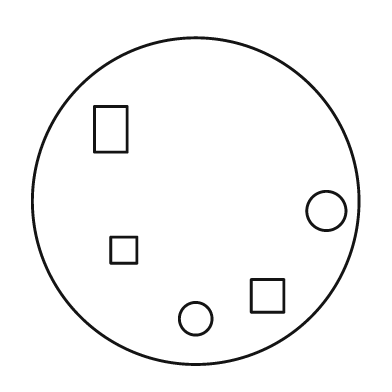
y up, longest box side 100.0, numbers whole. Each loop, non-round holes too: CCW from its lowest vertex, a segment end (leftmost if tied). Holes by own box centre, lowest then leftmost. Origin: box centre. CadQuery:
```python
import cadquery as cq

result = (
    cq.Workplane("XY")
    .moveTo(0.0, 0.0)
    .circle(50.0)
    .moveTo(0.0, -36.0)
    .circle(5.0)
    .moveTo(17.0, -34.0)
    .lineTo(27.0, -34.0)
    .lineTo(27.0, -24.0)
    .lineTo(17.0, -24.0)
    .close()
    .moveTo(-26.0, -19.0)
    .lineTo(-18.0, -19.0)
    .lineTo(-18.0, -11.0)
    .lineTo(-26.0, -11.0)
    .close()
    .moveTo(40.0, -3.0)
    .circle(6.0)
    .moveTo(-31.0, 15.0)
    .lineTo(-21.0, 15.0)
    .lineTo(-21.0, 29.0)
    .lineTo(-31.0, 29.0)
    .close()
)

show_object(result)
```